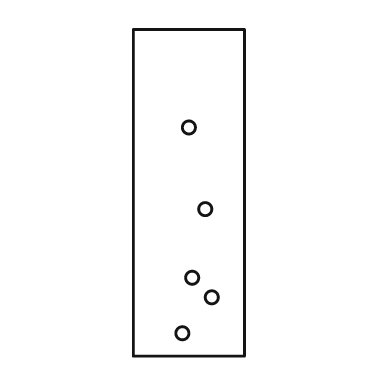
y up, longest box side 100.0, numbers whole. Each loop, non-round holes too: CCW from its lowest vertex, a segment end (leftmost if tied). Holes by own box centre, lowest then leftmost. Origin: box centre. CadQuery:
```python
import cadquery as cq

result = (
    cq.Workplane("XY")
    .moveTo(-17.0, -50.0)
    .lineTo(17.0, -50.0)
    .lineTo(17.0, 50.0)
    .lineTo(-17.0, 50.0)
    .close()
    .moveTo(-2.0, -43.0)
    .circle(2.0)
    .moveTo(7.0, -32.0)
    .circle(2.0)
    .moveTo(1.0, -26.0)
    .circle(2.0)
    .moveTo(5.0, -5.0)
    .circle(2.0)
    .moveTo(0.0, 20.0)
    .circle(2.0)
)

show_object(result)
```